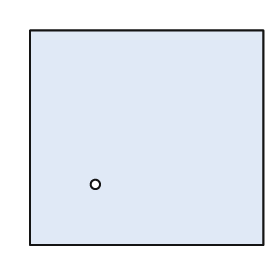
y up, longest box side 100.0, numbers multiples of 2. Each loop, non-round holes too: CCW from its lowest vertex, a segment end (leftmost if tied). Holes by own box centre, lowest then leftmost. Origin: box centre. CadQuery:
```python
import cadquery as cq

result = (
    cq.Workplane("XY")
    .moveTo(-50.0, -46.0)
    .lineTo(50.0, -46.0)
    .lineTo(50.0, 46.0)
    .lineTo(-50.0, 46.0)
    .close()
    .moveTo(-22.0, -20.0)
    .circle(2.0)
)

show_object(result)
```